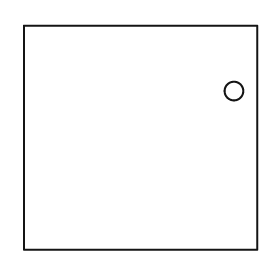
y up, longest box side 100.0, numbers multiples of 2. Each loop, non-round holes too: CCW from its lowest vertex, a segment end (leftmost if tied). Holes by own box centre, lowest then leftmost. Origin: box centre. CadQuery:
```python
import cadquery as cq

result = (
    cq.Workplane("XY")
    .moveTo(-50.0, -48.0)
    .lineTo(50.0, -48.0)
    .lineTo(50.0, 48.0)
    .lineTo(-50.0, 48.0)
    .close()
    .moveTo(40.0, 20.0)
    .circle(4.0)
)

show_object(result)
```